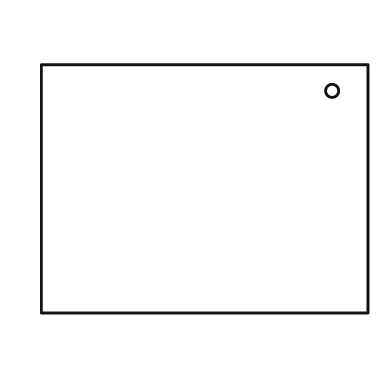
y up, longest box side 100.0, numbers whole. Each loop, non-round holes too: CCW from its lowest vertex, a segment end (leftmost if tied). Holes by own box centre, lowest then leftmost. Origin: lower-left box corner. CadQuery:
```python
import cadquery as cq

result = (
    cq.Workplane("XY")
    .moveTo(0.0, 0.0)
    .lineTo(100.0, 0.0)
    .lineTo(100.0, 76.0)
    .lineTo(0.0, 76.0)
    .close()
    .moveTo(89.0, 68.0)
    .circle(2.0)
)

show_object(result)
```